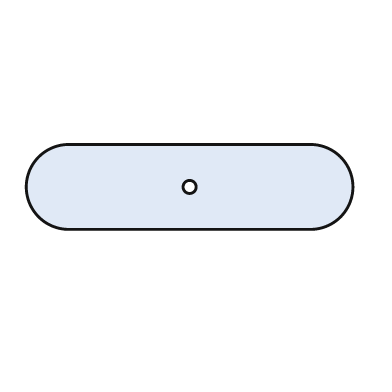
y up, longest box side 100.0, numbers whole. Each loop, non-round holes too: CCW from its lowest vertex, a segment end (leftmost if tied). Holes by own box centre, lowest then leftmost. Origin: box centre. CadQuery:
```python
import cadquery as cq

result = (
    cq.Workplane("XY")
    .moveTo(-37.0, -13.0)
    .lineTo(37.0, -13.0)
    .threePointArc((50.0, 0.0), (37.0, 13.0))
    .lineTo(-37.0, 13.0)
    .threePointArc((-50.0, 0.0), (-37.0, -13.0))
    .close()
    .moveTo(0.0, 0.0)
    .circle(2.0)
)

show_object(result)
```